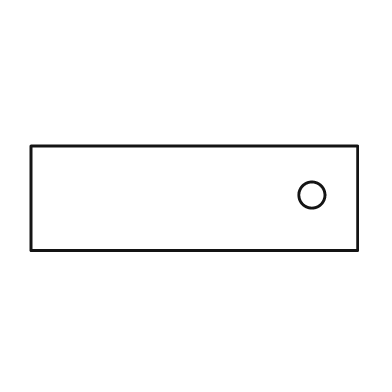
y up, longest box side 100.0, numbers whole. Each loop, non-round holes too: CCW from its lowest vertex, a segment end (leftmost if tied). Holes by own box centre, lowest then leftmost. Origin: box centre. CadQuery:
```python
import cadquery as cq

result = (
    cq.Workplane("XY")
    .moveTo(-50.0, -16.0)
    .lineTo(50.0, -16.0)
    .lineTo(50.0, 16.0)
    .lineTo(-50.0, 16.0)
    .close()
    .moveTo(36.0, 1.0)
    .circle(4.0)
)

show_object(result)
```